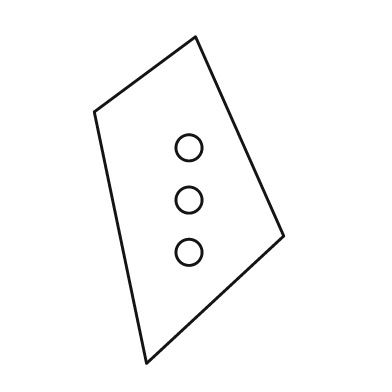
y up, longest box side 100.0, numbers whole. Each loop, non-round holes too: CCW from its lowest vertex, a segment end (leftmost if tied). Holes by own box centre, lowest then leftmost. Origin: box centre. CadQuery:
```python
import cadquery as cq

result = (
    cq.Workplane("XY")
    .moveTo(-13.0, -50.0)
    .lineTo(29.0, -11.0)
    .lineTo(2.0, 50.0)
    .lineTo(-29.0, 27.0)
    .close()
    .moveTo(0.0, -16.0)
    .circle(4.0)
    .moveTo(0.0, 0.0)
    .circle(4.0)
    .moveTo(0.0, 16.0)
    .circle(4.0)
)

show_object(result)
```